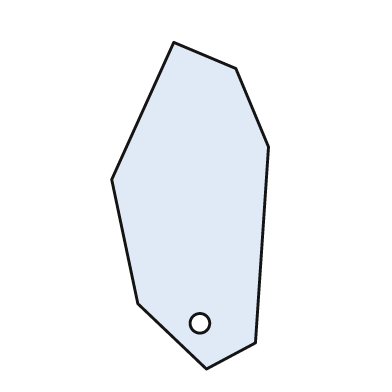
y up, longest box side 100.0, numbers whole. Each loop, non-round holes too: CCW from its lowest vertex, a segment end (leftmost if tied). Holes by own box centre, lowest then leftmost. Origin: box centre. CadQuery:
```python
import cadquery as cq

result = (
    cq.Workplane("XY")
    .moveTo(5.0, -50.0)
    .lineTo(20.0, -42.0)
    .lineTo(24.0, 18.0)
    .lineTo(14.0, 42.0)
    .lineTo(-5.0, 50.0)
    .lineTo(-24.0, 8.0)
    .lineTo(-16.0, -30.0)
    .close()
    .moveTo(3.0, -36.0)
    .circle(3.0)
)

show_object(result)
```